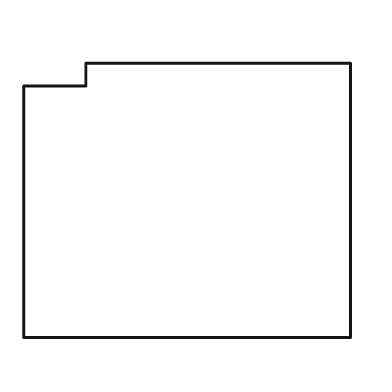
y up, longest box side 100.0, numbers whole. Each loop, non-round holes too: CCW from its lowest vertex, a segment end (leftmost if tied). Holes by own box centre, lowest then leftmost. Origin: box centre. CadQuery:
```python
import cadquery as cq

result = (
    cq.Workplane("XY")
    .moveTo(-50.0, -42.0)
    .lineTo(50.0, -42.0)
    .lineTo(50.0, 42.0)
    .lineTo(-31.0, 42.0)
    .lineTo(-31.0, 35.0)
    .lineTo(-50.0, 35.0)
    .close()
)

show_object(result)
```